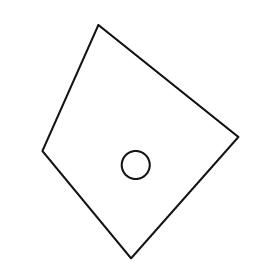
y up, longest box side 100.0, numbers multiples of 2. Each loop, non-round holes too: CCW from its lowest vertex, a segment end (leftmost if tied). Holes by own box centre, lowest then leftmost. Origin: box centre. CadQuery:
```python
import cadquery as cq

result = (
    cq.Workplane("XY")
    .moveTo(-4.0, -50.0)
    .lineTo(42.0, 2.0)
    .lineTo(-18.0, 50.0)
    .lineTo(-42.0, -4.0)
    .close()
    .moveTo(-2.0, -10.0)
    .circle(6.0)
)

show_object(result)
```